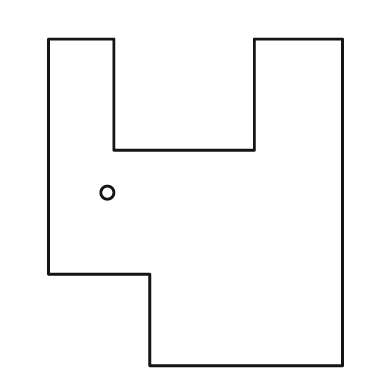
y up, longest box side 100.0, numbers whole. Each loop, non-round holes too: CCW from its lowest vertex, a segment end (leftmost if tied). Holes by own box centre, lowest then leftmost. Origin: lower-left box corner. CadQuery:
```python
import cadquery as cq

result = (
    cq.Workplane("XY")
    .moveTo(31.0, 0.0)
    .lineTo(90.0, 0.0)
    .lineTo(90.0, 100.0)
    .lineTo(63.0, 100.0)
    .lineTo(63.0, 66.0)
    .lineTo(20.0, 66.0)
    .lineTo(20.0, 100.0)
    .lineTo(0.0, 100.0)
    .lineTo(0.0, 28.0)
    .lineTo(31.0, 28.0)
    .close()
    .moveTo(18.0, 53.0)
    .circle(2.0)
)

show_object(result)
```